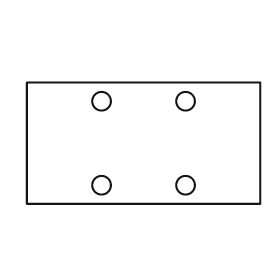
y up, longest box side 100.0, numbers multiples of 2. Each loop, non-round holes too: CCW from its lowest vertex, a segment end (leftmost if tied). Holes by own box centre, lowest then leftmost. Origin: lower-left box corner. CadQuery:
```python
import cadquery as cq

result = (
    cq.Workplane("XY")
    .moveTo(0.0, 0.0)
    .lineTo(100.0, 0.0)
    .lineTo(100.0, 52.0)
    .lineTo(0.0, 52.0)
    .close()
    .moveTo(32.0, 8.0)
    .circle(4.0)
    .moveTo(68.0, 8.0)
    .circle(4.0)
    .moveTo(32.0, 44.0)
    .circle(4.0)
    .moveTo(68.0, 44.0)
    .circle(4.0)
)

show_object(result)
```